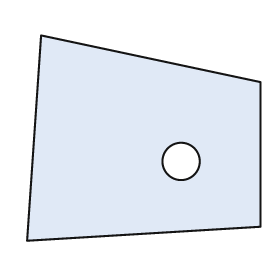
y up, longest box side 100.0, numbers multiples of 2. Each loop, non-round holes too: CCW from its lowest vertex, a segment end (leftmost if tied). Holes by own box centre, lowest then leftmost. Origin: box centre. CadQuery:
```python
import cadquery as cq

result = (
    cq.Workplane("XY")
    .moveTo(-50.0, -44.0)
    .lineTo(50.0, -38.0)
    .lineTo(50.0, 24.0)
    .lineTo(-44.0, 44.0)
    .close()
    .moveTo(16.0, -10.0)
    .circle(8.0)
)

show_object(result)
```